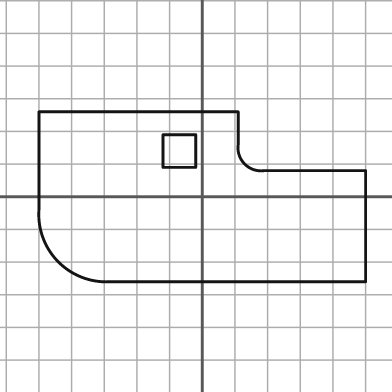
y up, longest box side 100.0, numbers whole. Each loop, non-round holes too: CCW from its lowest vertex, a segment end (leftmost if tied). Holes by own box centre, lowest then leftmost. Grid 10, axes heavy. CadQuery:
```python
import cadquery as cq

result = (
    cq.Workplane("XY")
    .moveTo(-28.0, -26.0)
    .lineTo(50.0, -26.0)
    .lineTo(50.0, 8.0)
    .lineTo(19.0, 8.0)
    .threePointArc((13.0, 10.0), (11.0, 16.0))
    .lineTo(11.0, 26.0)
    .lineTo(-50.0, 26.0)
    .lineTo(-50.0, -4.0)
    .threePointArc((-44.0, -20.0), (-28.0, -26.0))
    .close()
    .moveTo(-12.0, 9.0)
    .lineTo(-2.0, 9.0)
    .lineTo(-2.0, 19.0)
    .lineTo(-12.0, 19.0)
    .close()
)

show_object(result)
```